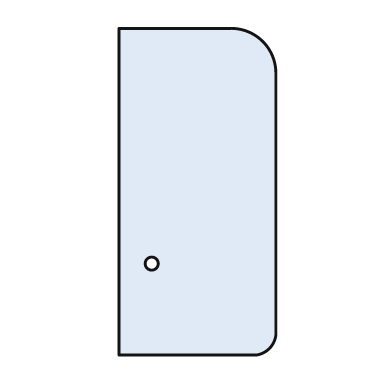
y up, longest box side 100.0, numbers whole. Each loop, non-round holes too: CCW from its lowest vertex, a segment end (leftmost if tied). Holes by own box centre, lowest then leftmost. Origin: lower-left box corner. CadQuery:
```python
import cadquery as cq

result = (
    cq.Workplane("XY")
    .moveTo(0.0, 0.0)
    .lineTo(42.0, 0.0)
    .threePointArc((46.0, 2.0), (48.0, 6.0))
    .lineTo(48.0, 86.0)
    .threePointArc((44.0, 96.0), (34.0, 100.0))
    .lineTo(0.0, 100.0)
    .close()
    .moveTo(10.0, 28.0)
    .circle(2.0)
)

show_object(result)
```